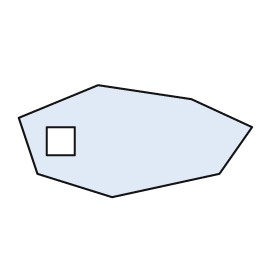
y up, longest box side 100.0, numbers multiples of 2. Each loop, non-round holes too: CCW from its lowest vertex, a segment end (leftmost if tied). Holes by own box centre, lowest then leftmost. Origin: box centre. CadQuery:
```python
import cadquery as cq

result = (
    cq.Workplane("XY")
    .moveTo(-10.0, -24.0)
    .lineTo(36.0, -14.0)
    .lineTo(50.0, 6.0)
    .lineTo(24.0, 18.0)
    .lineTo(-16.0, 24.0)
    .lineTo(-50.0, 10.0)
    .lineTo(-42.0, -14.0)
    .close()
    .moveTo(-38.0, -6.0)
    .lineTo(-26.0, -6.0)
    .lineTo(-26.0, 6.0)
    .lineTo(-38.0, 6.0)
    .close()
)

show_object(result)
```